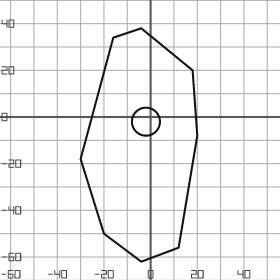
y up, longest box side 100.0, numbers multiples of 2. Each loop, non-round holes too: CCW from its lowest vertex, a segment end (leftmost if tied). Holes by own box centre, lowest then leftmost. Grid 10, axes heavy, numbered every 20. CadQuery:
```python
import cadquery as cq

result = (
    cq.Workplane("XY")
    .moveTo(-4.0, -62.0)
    .lineTo(12.0, -56.0)
    .lineTo(20.0, -8.0)
    .lineTo(18.0, 20.0)
    .lineTo(-4.0, 38.0)
    .lineTo(-16.0, 34.0)
    .lineTo(-30.0, -18.0)
    .lineTo(-20.0, -50.0)
    .close()
    .moveTo(-2.0, -2.0)
    .circle(6.0)
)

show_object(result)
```